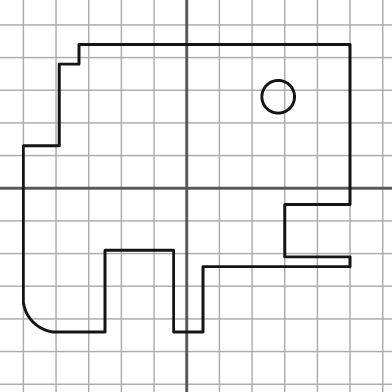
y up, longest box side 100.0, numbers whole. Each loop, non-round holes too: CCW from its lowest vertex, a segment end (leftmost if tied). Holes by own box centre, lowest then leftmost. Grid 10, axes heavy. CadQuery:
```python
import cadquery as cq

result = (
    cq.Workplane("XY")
    .moveTo(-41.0, -44.0)
    .lineTo(-25.0, -44.0)
    .lineTo(-25.0, -19.0)
    .lineTo(-4.0, -19.0)
    .lineTo(-4.0, -44.0)
    .lineTo(5.0, -44.0)
    .lineTo(5.0, -24.0)
    .lineTo(50.0, -24.0)
    .lineTo(50.0, -21.0)
    .lineTo(30.0, -21.0)
    .lineTo(30.0, -5.0)
    .lineTo(50.0, -5.0)
    .lineTo(50.0, 44.0)
    .lineTo(-33.0, 44.0)
    .lineTo(-33.0, 38.0)
    .lineTo(-39.0, 38.0)
    .lineTo(-39.0, 13.0)
    .lineTo(-50.0, 13.0)
    .lineTo(-50.0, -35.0)
    .threePointArc((-47.0, -41.0), (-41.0, -44.0))
    .close()
    .moveTo(28.0, 28.0)
    .circle(5.0)
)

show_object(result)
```